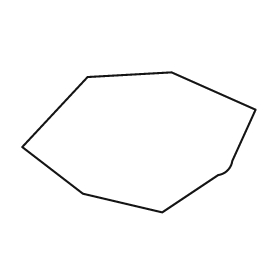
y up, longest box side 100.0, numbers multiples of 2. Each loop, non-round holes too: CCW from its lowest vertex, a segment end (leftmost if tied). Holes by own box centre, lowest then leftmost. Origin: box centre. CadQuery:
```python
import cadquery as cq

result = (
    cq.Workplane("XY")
    .moveTo(10.0, -30.0)
    .lineTo(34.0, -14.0)
    .threePointArc((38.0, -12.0), (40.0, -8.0))
    .lineTo(50.0, 14.0)
    .lineTo(14.0, 30.0)
    .lineTo(-22.0, 28.0)
    .lineTo(-50.0, -2.0)
    .lineTo(-24.0, -22.0)
    .close()
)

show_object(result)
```